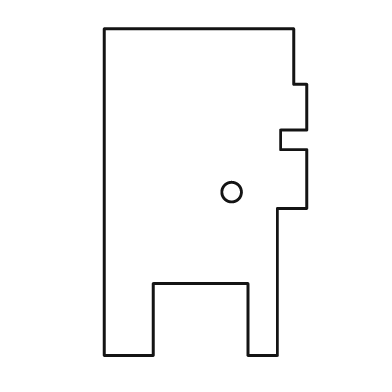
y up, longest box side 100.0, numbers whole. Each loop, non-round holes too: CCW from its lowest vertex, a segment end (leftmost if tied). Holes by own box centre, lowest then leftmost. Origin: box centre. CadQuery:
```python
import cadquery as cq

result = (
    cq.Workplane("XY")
    .moveTo(-31.0, -50.0)
    .lineTo(-16.0, -50.0)
    .lineTo(-16.0, -28.0)
    .lineTo(13.0, -28.0)
    .lineTo(13.0, -50.0)
    .lineTo(22.0, -50.0)
    .lineTo(22.0, -5.0)
    .lineTo(31.0, -5.0)
    .lineTo(31.0, 13.0)
    .lineTo(23.0, 13.0)
    .lineTo(23.0, 19.0)
    .lineTo(31.0, 19.0)
    .lineTo(31.0, 33.0)
    .lineTo(27.0, 33.0)
    .lineTo(27.0, 50.0)
    .lineTo(-31.0, 50.0)
    .close()
    .moveTo(8.0, 0.0)
    .circle(3.0)
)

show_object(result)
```